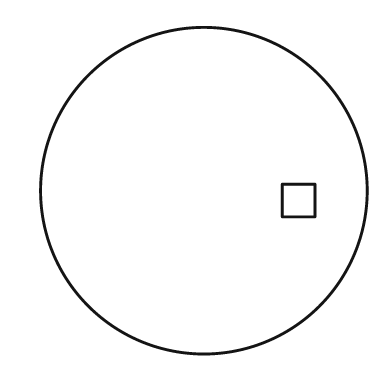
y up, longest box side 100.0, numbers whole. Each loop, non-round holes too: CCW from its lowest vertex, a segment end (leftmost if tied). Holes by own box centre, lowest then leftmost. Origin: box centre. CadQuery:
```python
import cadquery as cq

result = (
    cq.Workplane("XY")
    .moveTo(0.0, 0.0)
    .circle(50.0)
    .moveTo(24.0, -8.0)
    .lineTo(34.0, -8.0)
    .lineTo(34.0, 2.0)
    .lineTo(24.0, 2.0)
    .close()
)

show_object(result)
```